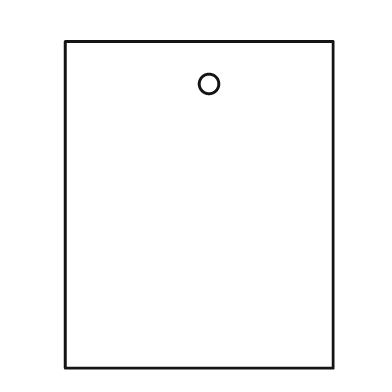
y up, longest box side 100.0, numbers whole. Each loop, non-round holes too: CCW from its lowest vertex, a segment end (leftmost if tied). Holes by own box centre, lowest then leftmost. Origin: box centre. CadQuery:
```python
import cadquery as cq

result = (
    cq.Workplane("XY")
    .moveTo(-41.0, -50.0)
    .lineTo(41.0, -50.0)
    .lineTo(41.0, 50.0)
    .lineTo(-41.0, 50.0)
    .close()
    .moveTo(3.0, 37.0)
    .circle(3.0)
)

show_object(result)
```